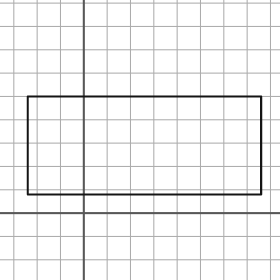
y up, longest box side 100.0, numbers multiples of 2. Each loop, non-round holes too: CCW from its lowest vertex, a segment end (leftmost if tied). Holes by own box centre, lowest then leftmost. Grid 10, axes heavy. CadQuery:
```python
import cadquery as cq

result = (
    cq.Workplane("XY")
    .moveTo(-24.0, 8.0)
    .lineTo(76.0, 8.0)
    .lineTo(76.0, 50.0)
    .lineTo(-24.0, 50.0)
    .close()
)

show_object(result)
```